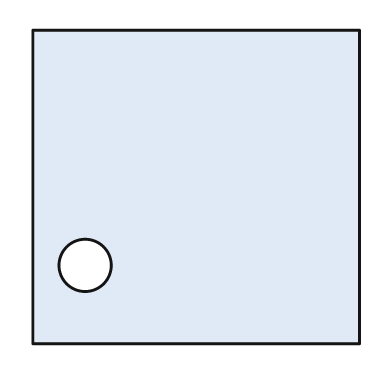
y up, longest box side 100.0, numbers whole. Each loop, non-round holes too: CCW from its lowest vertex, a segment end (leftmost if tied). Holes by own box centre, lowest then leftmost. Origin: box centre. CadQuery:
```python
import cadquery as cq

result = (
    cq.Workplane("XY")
    .moveTo(-50.0, -48.0)
    .lineTo(50.0, -48.0)
    .lineTo(50.0, 48.0)
    .lineTo(-50.0, 48.0)
    .close()
    .moveTo(-34.0, -24.0)
    .circle(8.0)
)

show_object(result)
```